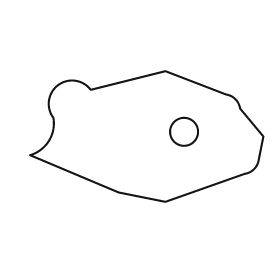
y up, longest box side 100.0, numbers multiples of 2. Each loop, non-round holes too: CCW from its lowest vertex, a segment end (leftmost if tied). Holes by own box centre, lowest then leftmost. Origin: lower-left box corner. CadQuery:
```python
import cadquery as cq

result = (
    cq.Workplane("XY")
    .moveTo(58.0, 0.0)
    .lineTo(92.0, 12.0)
    .threePointArc((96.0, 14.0), (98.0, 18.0))
    .lineTo(100.0, 28.0)
    .lineTo(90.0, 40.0)
    .threePointArc((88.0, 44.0), (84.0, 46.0))
    .lineTo(58.0, 56.0)
    .lineTo(26.0, 48.0)
    .threePointArc((12.0, 50.0), (10.0, 36.0))
    .threePointArc((8.0, 26.0), (0.0, 20.0))
    .lineTo(38.0, 4.0)
    .close()
    .moveTo(66.0, 30.0)
    .circle(6.0)
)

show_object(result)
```